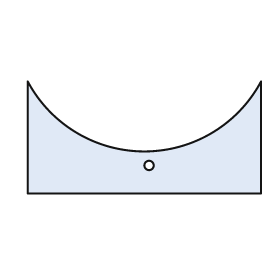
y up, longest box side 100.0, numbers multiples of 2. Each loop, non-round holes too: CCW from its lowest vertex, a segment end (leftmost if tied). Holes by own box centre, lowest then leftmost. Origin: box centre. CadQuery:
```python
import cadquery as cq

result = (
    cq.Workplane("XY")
    .moveTo(-50.0, -24.0)
    .lineTo(50.0, -24.0)
    .lineTo(50.0, 24.0)
    .threePointArc((0.0, -6.0), (-50.0, 24.0))
    .close()
    .moveTo(2.0, -12.0)
    .circle(2.0)
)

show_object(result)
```